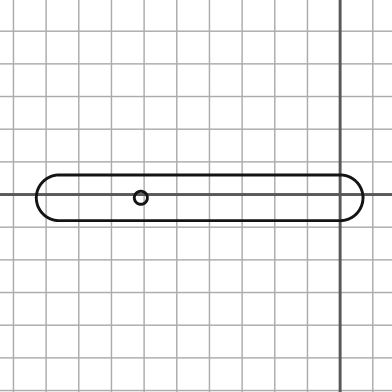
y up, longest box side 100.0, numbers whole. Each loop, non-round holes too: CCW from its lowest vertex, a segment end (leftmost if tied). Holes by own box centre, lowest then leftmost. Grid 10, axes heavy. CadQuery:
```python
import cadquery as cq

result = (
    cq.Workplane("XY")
    .moveTo(-86.0, -8.0)
    .lineTo(0.0, -8.0)
    .threePointArc((7.0, -1.0), (0.0, 6.0))
    .lineTo(-86.0, 6.0)
    .threePointArc((-93.0, -1.0), (-86.0, -8.0))
    .close()
    .moveTo(-61.0, -1.0)
    .circle(2.0)
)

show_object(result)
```